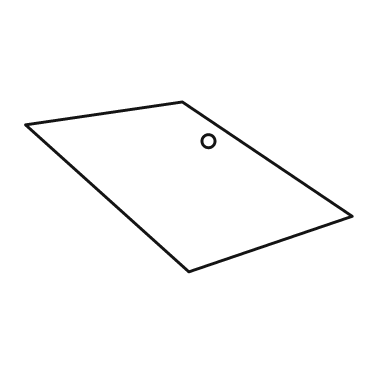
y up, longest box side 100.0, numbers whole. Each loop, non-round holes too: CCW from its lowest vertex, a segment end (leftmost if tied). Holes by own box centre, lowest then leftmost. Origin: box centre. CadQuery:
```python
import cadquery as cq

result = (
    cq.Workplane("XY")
    .moveTo(0.0, -26.0)
    .lineTo(50.0, -9.0)
    .lineTo(-2.0, 26.0)
    .lineTo(-50.0, 19.0)
    .close()
    .moveTo(6.0, 14.0)
    .circle(2.0)
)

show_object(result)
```